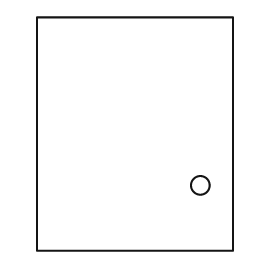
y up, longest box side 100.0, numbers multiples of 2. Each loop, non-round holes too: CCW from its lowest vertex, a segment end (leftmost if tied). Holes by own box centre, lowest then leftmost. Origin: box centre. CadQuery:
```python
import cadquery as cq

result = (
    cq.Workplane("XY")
    .moveTo(-42.0, -50.0)
    .lineTo(42.0, -50.0)
    .lineTo(42.0, 50.0)
    .lineTo(-42.0, 50.0)
    .close()
    .moveTo(28.0, -22.0)
    .circle(4.0)
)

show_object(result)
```